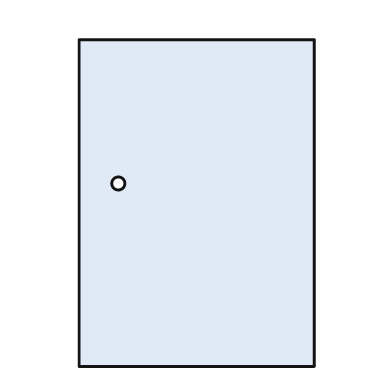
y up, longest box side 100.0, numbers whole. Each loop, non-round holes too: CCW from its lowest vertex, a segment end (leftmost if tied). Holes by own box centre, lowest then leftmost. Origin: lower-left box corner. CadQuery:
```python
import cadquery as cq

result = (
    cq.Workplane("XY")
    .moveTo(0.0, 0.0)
    .lineTo(72.0, 0.0)
    .lineTo(72.0, 100.0)
    .lineTo(0.0, 100.0)
    .close()
    .moveTo(12.0, 56.0)
    .circle(2.0)
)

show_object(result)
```